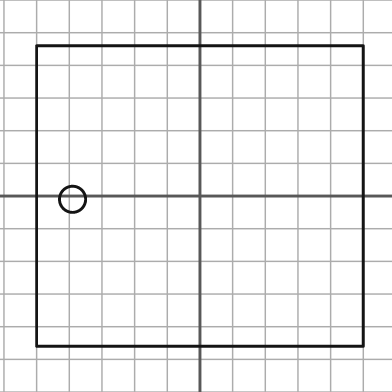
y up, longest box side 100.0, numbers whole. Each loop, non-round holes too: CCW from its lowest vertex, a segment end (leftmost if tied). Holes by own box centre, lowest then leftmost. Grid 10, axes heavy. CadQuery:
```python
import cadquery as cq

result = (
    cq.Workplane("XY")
    .moveTo(-50.0, -46.0)
    .lineTo(50.0, -46.0)
    .lineTo(50.0, 46.0)
    .lineTo(-50.0, 46.0)
    .close()
    .moveTo(-39.0, -1.0)
    .circle(4.0)
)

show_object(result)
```